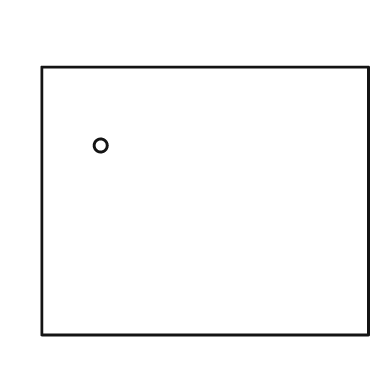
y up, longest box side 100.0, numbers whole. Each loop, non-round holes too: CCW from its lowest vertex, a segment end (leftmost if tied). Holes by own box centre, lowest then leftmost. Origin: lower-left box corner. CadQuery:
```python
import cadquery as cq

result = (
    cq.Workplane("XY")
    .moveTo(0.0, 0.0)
    .lineTo(100.0, 0.0)
    .lineTo(100.0, 82.0)
    .lineTo(0.0, 82.0)
    .close()
    .moveTo(18.0, 58.0)
    .circle(2.0)
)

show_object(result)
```